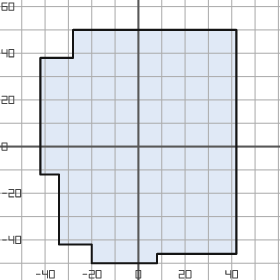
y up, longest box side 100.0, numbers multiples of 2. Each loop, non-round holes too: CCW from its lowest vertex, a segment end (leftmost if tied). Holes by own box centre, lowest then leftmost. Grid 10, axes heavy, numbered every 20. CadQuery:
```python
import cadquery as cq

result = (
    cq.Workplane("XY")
    .moveTo(-20.0, -50.0)
    .lineTo(8.0, -50.0)
    .lineTo(8.0, -46.0)
    .lineTo(42.0, -46.0)
    .lineTo(42.0, 50.0)
    .lineTo(-28.0, 50.0)
    .lineTo(-28.0, 38.0)
    .lineTo(-42.0, 38.0)
    .lineTo(-42.0, -12.0)
    .lineTo(-34.0, -12.0)
    .lineTo(-34.0, -42.0)
    .lineTo(-20.0, -42.0)
    .close()
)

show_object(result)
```